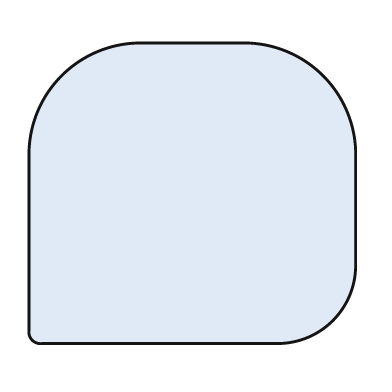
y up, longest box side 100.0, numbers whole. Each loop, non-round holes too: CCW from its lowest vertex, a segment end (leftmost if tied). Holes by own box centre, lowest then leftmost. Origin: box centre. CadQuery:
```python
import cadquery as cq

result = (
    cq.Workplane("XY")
    .moveTo(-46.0, -46.0)
    .lineTo(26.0, -46.0)
    .threePointArc((43.0, -39.0), (50.0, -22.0))
    .lineTo(50.0, 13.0)
    .threePointArc((40.0, 36.0), (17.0, 46.0))
    .lineTo(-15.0, 46.0)
    .threePointArc((-40.0, 36.0), (-50.0, 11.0))
    .lineTo(-50.0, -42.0)
    .threePointArc((-49.0, -45.0), (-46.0, -46.0))
    .close()
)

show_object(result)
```